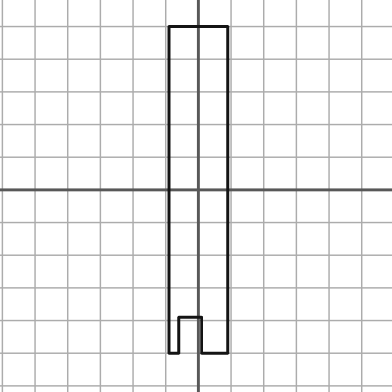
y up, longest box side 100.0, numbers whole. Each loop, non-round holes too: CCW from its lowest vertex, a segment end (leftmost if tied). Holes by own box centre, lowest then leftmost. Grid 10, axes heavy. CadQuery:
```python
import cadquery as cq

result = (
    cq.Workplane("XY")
    .moveTo(-9.0, -50.0)
    .lineTo(-6.0, -50.0)
    .lineTo(-6.0, -39.0)
    .lineTo(1.0, -39.0)
    .lineTo(1.0, -50.0)
    .lineTo(9.0, -50.0)
    .lineTo(9.0, 50.0)
    .lineTo(-9.0, 50.0)
    .close()
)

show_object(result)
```